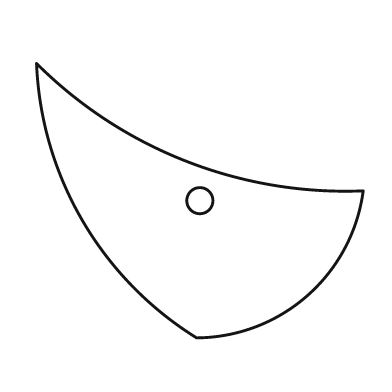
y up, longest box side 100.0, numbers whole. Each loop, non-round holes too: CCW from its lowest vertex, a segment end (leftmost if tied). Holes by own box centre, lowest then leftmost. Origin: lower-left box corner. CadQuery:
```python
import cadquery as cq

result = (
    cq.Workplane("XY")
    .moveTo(49.0, 0.0)
    .threePointArc((83.0, 13.0), (100.0, 45.0))
    .threePointArc((46.0, 54.0), (0.0, 84.0))
    .threePointArc((14.0, 36.0), (49.0, 0.0))
    .close()
    .moveTo(50.0, 42.0)
    .circle(4.0)
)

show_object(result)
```